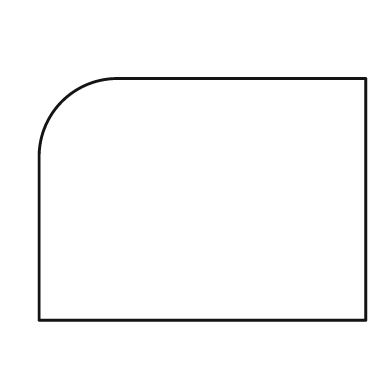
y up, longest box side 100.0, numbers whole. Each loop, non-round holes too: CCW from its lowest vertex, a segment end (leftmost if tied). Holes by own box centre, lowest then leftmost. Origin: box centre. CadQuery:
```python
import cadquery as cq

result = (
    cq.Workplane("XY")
    .moveTo(-50.0, -37.0)
    .lineTo(50.0, -37.0)
    .lineTo(50.0, 37.0)
    .lineTo(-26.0, 37.0)
    .threePointArc((-43.0, 30.0), (-50.0, 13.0))
    .close()
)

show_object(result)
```